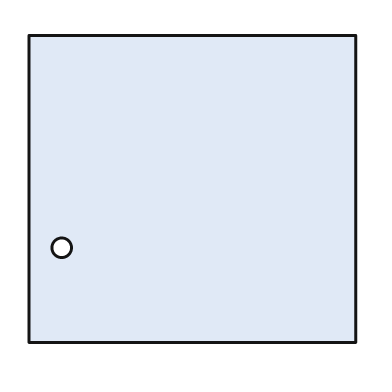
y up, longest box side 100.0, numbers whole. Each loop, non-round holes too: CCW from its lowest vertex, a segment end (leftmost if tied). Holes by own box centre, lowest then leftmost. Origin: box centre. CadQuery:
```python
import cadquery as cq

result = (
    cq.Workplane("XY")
    .moveTo(-50.0, -47.0)
    .lineTo(50.0, -47.0)
    .lineTo(50.0, 47.0)
    .lineTo(-50.0, 47.0)
    .close()
    .moveTo(-40.0, -18.0)
    .circle(3.0)
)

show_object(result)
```